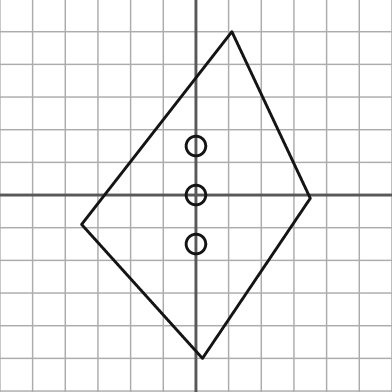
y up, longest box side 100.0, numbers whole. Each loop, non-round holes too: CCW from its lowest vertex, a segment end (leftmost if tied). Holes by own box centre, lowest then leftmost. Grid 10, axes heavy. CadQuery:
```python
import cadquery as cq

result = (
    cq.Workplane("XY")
    .moveTo(2.0, -50.0)
    .lineTo(35.0, -1.0)
    .lineTo(11.0, 50.0)
    .lineTo(-35.0, -9.0)
    .close()
    .moveTo(0.0, -15.0)
    .circle(3.0)
    .moveTo(0.0, 0.0)
    .circle(3.0)
    .moveTo(0.0, 15.0)
    .circle(3.0)
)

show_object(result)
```